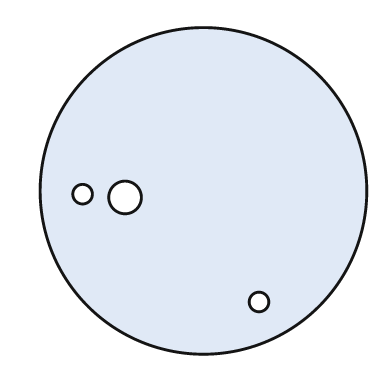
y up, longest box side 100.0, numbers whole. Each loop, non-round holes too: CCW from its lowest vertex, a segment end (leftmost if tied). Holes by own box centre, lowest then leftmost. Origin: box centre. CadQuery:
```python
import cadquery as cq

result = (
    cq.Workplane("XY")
    .moveTo(0.0, 0.0)
    .circle(50.0)
    .moveTo(17.0, -34.0)
    .circle(3.0)
    .moveTo(-24.0, -2.0)
    .circle(5.0)
    .moveTo(-37.0, -1.0)
    .circle(3.0)
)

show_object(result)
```